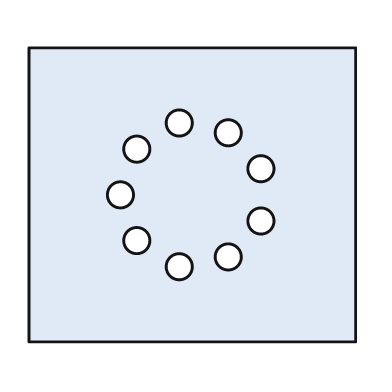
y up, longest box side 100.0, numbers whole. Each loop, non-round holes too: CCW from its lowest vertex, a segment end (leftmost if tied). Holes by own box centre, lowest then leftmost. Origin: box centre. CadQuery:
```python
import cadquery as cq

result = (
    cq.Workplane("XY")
    .moveTo(-50.0, -45.0)
    .lineTo(50.0, -45.0)
    .lineTo(50.0, 45.0)
    .lineTo(-50.0, 45.0)
    .close()
    .moveTo(-4.0, -22.0)
    .circle(4.0)
    .moveTo(11.0, -19.0)
    .circle(4.0)
    .moveTo(-17.0, -14.0)
    .circle(4.0)
    .moveTo(21.0, -8.0)
    .circle(4.0)
    .moveTo(-22.0, 0.0)
    .circle(4.0)
    .moveTo(21.0, 8.0)
    .circle(4.0)
    .moveTo(-17.0, 14.0)
    .circle(4.0)
    .moveTo(11.0, 19.0)
    .circle(4.0)
    .moveTo(-4.0, 22.0)
    .circle(4.0)
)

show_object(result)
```